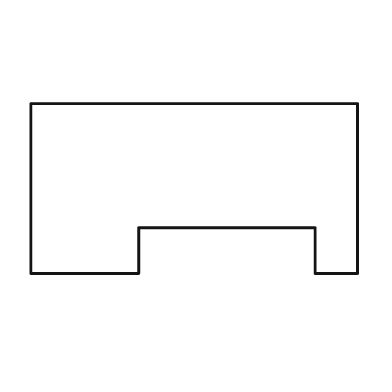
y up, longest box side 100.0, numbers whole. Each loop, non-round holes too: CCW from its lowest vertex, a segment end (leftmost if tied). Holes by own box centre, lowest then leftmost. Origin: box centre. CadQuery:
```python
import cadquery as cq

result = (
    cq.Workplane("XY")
    .moveTo(-50.0, -26.0)
    .lineTo(-17.0, -26.0)
    .lineTo(-17.0, -12.0)
    .lineTo(37.0, -12.0)
    .lineTo(37.0, -26.0)
    .lineTo(50.0, -26.0)
    .lineTo(50.0, 26.0)
    .lineTo(-50.0, 26.0)
    .close()
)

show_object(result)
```